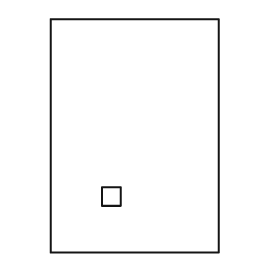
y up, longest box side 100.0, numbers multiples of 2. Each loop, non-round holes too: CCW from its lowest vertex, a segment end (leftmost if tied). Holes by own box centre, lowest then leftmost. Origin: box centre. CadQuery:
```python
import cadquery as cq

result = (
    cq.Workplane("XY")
    .moveTo(-36.0, -50.0)
    .lineTo(36.0, -50.0)
    .lineTo(36.0, 50.0)
    .lineTo(-36.0, 50.0)
    .close()
    .moveTo(-14.0, -30.0)
    .lineTo(-6.0, -30.0)
    .lineTo(-6.0, -22.0)
    .lineTo(-14.0, -22.0)
    .close()
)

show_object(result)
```